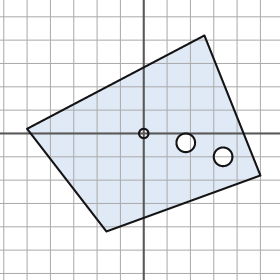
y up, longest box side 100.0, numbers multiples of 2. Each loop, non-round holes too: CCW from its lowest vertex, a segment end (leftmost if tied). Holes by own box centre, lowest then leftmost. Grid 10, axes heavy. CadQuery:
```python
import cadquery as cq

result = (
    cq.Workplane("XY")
    .moveTo(-16.0, -42.0)
    .lineTo(50.0, -18.0)
    .lineTo(26.0, 42.0)
    .lineTo(-50.0, 2.0)
    .close()
    .moveTo(34.0, -10.0)
    .circle(4.0)
    .moveTo(18.0, -4.0)
    .circle(4.0)
    .moveTo(0.0, 0.0)
    .circle(2.0)
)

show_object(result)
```